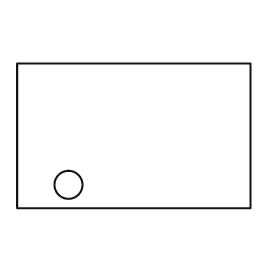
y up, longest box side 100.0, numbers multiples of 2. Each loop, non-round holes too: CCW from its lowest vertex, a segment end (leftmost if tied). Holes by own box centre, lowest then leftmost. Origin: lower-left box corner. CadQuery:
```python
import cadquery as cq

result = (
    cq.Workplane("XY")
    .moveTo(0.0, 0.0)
    .lineTo(100.0, 0.0)
    .lineTo(100.0, 62.0)
    .lineTo(0.0, 62.0)
    .close()
    .moveTo(22.0, 10.0)
    .circle(6.0)
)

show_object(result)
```